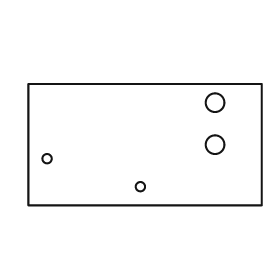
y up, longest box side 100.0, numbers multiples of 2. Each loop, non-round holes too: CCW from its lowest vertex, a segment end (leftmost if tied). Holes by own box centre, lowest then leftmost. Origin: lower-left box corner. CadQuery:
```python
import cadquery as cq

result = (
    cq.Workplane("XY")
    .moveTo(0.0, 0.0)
    .lineTo(100.0, 0.0)
    .lineTo(100.0, 52.0)
    .lineTo(0.0, 52.0)
    .close()
    .moveTo(48.0, 8.0)
    .circle(2.0)
    .moveTo(8.0, 20.0)
    .circle(2.0)
    .moveTo(80.0, 26.0)
    .circle(4.0)
    .moveTo(80.0, 44.0)
    .circle(4.0)
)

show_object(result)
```